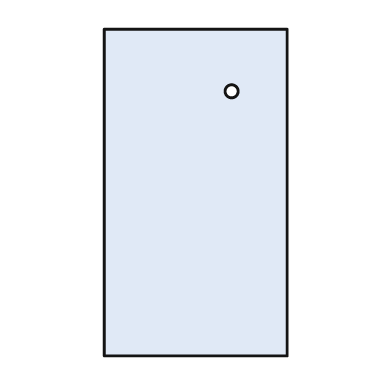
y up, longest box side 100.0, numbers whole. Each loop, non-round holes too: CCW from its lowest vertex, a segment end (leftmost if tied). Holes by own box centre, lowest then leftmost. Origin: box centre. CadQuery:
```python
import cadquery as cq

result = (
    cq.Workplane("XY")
    .moveTo(-28.0, -50.0)
    .lineTo(28.0, -50.0)
    .lineTo(28.0, 50.0)
    .lineTo(-28.0, 50.0)
    .close()
    .moveTo(11.0, 31.0)
    .circle(2.0)
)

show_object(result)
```